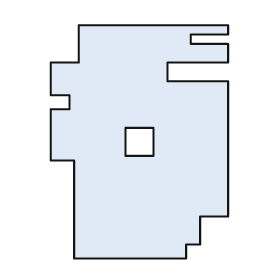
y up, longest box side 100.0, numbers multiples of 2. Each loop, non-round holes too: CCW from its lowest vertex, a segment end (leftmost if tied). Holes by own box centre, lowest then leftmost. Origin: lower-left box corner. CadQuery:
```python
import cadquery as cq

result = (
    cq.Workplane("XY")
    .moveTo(10.0, 0.0)
    .lineTo(58.0, 0.0)
    .lineTo(58.0, 6.0)
    .lineTo(64.0, 6.0)
    .lineTo(64.0, 18.0)
    .lineTo(76.0, 18.0)
    .lineTo(76.0, 76.0)
    .lineTo(50.0, 76.0)
    .lineTo(50.0, 84.0)
    .lineTo(76.0, 84.0)
    .lineTo(76.0, 92.0)
    .lineTo(60.0, 92.0)
    .lineTo(60.0, 96.0)
    .lineTo(76.0, 96.0)
    .lineTo(76.0, 100.0)
    .lineTo(12.0, 100.0)
    .lineTo(12.0, 84.0)
    .lineTo(0.0, 84.0)
    .lineTo(0.0, 70.0)
    .lineTo(8.0, 70.0)
    .lineTo(8.0, 64.0)
    .lineTo(0.0, 64.0)
    .lineTo(0.0, 42.0)
    .lineTo(10.0, 42.0)
    .close()
    .moveTo(32.0, 44.0)
    .lineTo(44.0, 44.0)
    .lineTo(44.0, 56.0)
    .lineTo(32.0, 56.0)
    .close()
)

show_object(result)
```